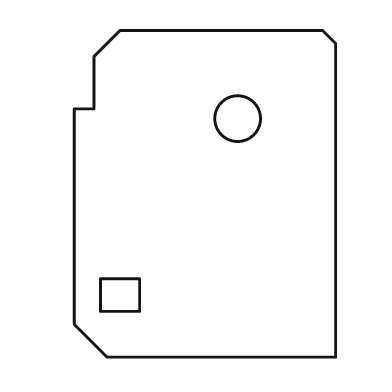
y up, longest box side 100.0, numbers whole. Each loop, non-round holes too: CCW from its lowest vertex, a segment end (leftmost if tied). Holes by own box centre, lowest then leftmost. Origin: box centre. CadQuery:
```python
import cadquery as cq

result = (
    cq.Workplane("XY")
    .moveTo(-30.0, -50.0)
    .lineTo(40.0, -50.0)
    .lineTo(40.0, 46.0)
    .lineTo(36.0, 50.0)
    .lineTo(-26.0, 50.0)
    .lineTo(-34.0, 42.0)
    .lineTo(-34.0, 26.0)
    .lineTo(-40.0, 26.0)
    .lineTo(-40.0, -40.0)
    .close()
    .moveTo(-32.0, -36.0)
    .lineTo(-20.0, -36.0)
    .lineTo(-20.0, -26.0)
    .lineTo(-32.0, -26.0)
    .close()
    .moveTo(10.0, 23.0)
    .circle(7.0)
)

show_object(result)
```